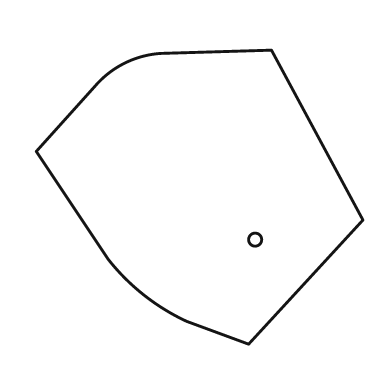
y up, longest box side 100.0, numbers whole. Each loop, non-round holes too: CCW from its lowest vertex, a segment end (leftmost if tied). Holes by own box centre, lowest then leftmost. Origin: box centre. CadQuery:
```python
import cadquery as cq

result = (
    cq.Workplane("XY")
    .moveTo(15.0, -45.0)
    .lineTo(50.0, -7.0)
    .lineTo(22.0, 45.0)
    .lineTo(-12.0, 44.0)
    .threePointArc((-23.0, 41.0), (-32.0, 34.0))
    .lineTo(-50.0, 14.0)
    .lineTo(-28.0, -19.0)
    .threePointArc((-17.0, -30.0), (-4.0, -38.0))
    .close()
    .moveTo(17.0, -13.0)
    .circle(2.0)
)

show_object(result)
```